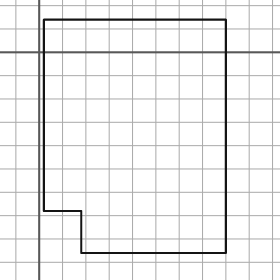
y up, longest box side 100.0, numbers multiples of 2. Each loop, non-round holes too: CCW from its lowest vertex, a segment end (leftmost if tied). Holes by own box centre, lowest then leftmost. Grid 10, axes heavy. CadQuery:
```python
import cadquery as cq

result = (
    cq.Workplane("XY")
    .moveTo(18.0, -86.0)
    .lineTo(80.0, -86.0)
    .lineTo(80.0, 14.0)
    .lineTo(2.0, 14.0)
    .lineTo(2.0, -68.0)
    .lineTo(18.0, -68.0)
    .close()
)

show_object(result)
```